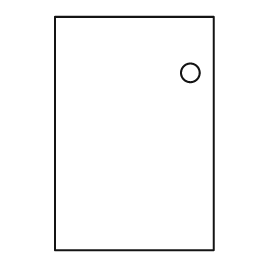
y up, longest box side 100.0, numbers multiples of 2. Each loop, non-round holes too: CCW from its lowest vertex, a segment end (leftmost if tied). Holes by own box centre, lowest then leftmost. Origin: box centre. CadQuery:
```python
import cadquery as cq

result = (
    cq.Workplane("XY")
    .moveTo(-34.0, -50.0)
    .lineTo(34.0, -50.0)
    .lineTo(34.0, 50.0)
    .lineTo(-34.0, 50.0)
    .close()
    .moveTo(24.0, 26.0)
    .circle(4.0)
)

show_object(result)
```